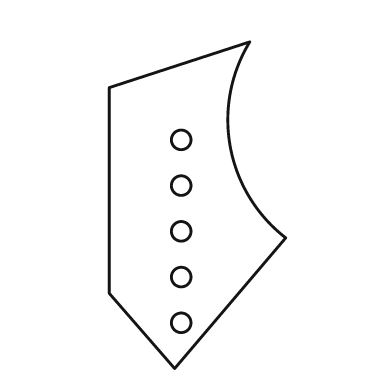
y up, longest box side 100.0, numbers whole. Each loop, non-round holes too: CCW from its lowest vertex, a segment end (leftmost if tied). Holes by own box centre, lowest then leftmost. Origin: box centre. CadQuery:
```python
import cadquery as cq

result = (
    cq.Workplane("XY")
    .moveTo(-7.0, -50.0)
    .lineTo(27.0, -10.0)
    .threePointArc((10.0, 18.0), (16.0, 50.0))
    .lineTo(-27.0, 36.0)
    .lineTo(-27.0, -27.0)
    .close()
    .moveTo(-5.0, -36.0)
    .circle(3.0)
    .moveTo(-5.0, -22.0)
    .circle(3.0)
    .moveTo(-5.0, -8.0)
    .circle(3.0)
    .moveTo(-5.0, 6.0)
    .circle(3.0)
    .moveTo(-5.0, 20.0)
    .circle(3.0)
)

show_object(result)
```